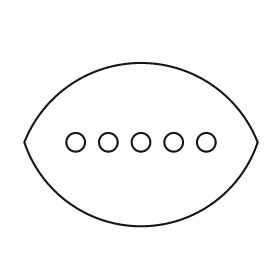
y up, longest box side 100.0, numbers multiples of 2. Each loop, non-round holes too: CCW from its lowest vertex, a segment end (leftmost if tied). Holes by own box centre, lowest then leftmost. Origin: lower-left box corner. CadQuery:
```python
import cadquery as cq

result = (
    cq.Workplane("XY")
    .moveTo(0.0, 36.0)
    .threePointArc((50.0, 0.0), (100.0, 36.0))
    .threePointArc((50.0, 70.0), (0.0, 36.0))
    .close()
    .moveTo(22.0, 36.0)
    .circle(4.0)
    .moveTo(36.0, 36.0)
    .circle(4.0)
    .moveTo(50.0, 36.0)
    .circle(4.0)
    .moveTo(64.0, 36.0)
    .circle(4.0)
    .moveTo(78.0, 36.0)
    .circle(4.0)
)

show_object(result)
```